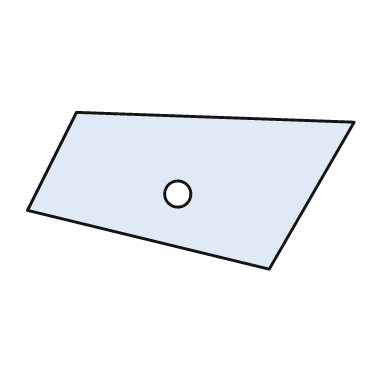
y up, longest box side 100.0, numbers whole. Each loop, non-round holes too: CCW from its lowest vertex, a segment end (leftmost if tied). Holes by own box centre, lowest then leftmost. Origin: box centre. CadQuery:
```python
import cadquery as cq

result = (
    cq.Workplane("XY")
    .moveTo(24.0, -24.0)
    .lineTo(50.0, 21.0)
    .lineTo(-35.0, 24.0)
    .lineTo(-50.0, -6.0)
    .close()
    .moveTo(-4.0, -1.0)
    .circle(4.0)
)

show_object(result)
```